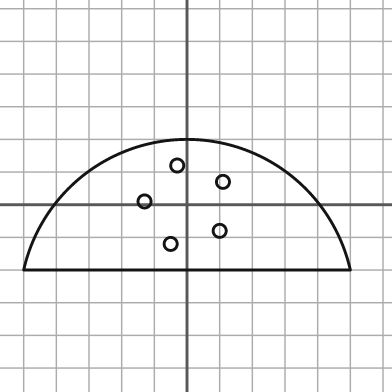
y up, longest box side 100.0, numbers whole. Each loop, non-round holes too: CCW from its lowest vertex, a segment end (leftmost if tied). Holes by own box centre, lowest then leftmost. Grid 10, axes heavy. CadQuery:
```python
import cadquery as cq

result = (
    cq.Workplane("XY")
    .moveTo(-50.0, -20.0)
    .lineTo(50.0, -20.0)
    .threePointArc((0.0, 20.0), (-50.0, -20.0))
    .close()
    .moveTo(-5.0, -12.0)
    .circle(2.0)
    .moveTo(10.0, -8.0)
    .circle(2.0)
    .moveTo(-13.0, 1.0)
    .circle(2.0)
    .moveTo(11.0, 7.0)
    .circle(2.0)
    .moveTo(-3.0, 12.0)
    .circle(2.0)
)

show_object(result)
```